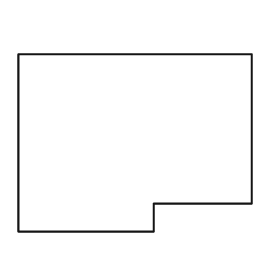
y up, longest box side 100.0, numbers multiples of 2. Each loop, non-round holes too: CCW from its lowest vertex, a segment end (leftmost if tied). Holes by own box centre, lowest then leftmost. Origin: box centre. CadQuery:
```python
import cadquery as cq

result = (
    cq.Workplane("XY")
    .moveTo(-50.0, -38.0)
    .lineTo(8.0, -38.0)
    .lineTo(8.0, -26.0)
    .lineTo(50.0, -26.0)
    .lineTo(50.0, 38.0)
    .lineTo(-50.0, 38.0)
    .close()
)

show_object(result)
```